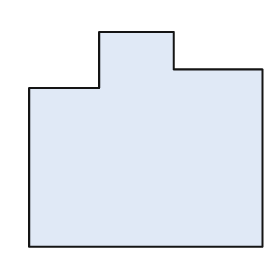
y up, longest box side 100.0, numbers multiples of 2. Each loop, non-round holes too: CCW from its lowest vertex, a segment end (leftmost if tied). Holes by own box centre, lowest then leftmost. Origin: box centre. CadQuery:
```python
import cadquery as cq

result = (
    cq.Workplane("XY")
    .moveTo(-50.0, -46.0)
    .lineTo(50.0, -46.0)
    .lineTo(50.0, 30.0)
    .lineTo(12.0, 30.0)
    .lineTo(12.0, 46.0)
    .lineTo(-20.0, 46.0)
    .lineTo(-20.0, 22.0)
    .lineTo(-50.0, 22.0)
    .close()
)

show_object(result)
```